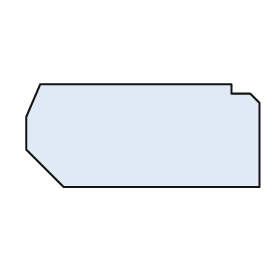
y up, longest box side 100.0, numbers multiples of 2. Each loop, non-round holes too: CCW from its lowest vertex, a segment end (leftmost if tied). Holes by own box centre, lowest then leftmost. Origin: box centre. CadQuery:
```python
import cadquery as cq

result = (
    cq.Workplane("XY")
    .moveTo(-34.0, -22.0)
    .lineTo(50.0, -22.0)
    .lineTo(50.0, 14.0)
    .lineTo(46.0, 18.0)
    .lineTo(38.0, 18.0)
    .lineTo(38.0, 22.0)
    .lineTo(-44.0, 22.0)
    .lineTo(-50.0, 8.0)
    .lineTo(-50.0, -6.0)
    .close()
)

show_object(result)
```